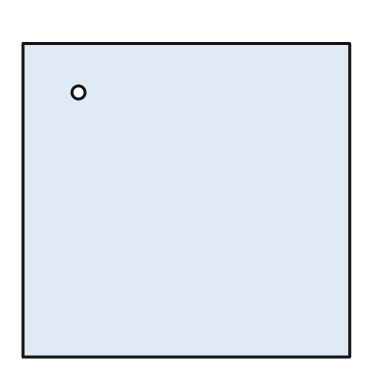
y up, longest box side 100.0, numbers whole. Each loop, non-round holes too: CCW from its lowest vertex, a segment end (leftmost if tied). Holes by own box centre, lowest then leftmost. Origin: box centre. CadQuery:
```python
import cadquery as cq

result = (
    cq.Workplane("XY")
    .moveTo(-50.0, -48.0)
    .lineTo(50.0, -48.0)
    .lineTo(50.0, 48.0)
    .lineTo(-50.0, 48.0)
    .close()
    .moveTo(-33.0, 33.0)
    .circle(2.0)
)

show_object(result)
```